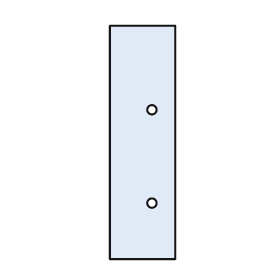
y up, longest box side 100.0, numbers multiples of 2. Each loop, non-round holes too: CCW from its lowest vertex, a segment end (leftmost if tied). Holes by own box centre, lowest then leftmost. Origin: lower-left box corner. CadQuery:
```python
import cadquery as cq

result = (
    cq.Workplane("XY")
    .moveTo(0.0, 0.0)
    .lineTo(28.0, 0.0)
    .lineTo(28.0, 100.0)
    .lineTo(0.0, 100.0)
    .close()
    .moveTo(18.0, 24.0)
    .circle(2.0)
    .moveTo(18.0, 64.0)
    .circle(2.0)
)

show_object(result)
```